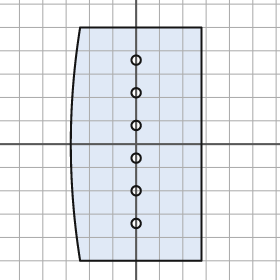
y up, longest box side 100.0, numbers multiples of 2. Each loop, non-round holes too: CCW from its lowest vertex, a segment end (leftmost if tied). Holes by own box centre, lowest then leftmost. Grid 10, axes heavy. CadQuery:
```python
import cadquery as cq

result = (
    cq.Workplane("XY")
    .moveTo(-24.0, -50.0)
    .lineTo(28.0, -50.0)
    .lineTo(28.0, 50.0)
    .lineTo(-24.0, 50.0)
    .threePointArc((-28.0, 0.0), (-24.0, -50.0))
    .close()
    .moveTo(0.0, -34.0)
    .circle(2.0)
    .moveTo(0.0, -20.0)
    .circle(2.0)
    .moveTo(0.0, -6.0)
    .circle(2.0)
    .moveTo(0.0, 8.0)
    .circle(2.0)
    .moveTo(0.0, 22.0)
    .circle(2.0)
    .moveTo(0.0, 36.0)
    .circle(2.0)
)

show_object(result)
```